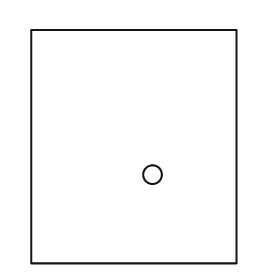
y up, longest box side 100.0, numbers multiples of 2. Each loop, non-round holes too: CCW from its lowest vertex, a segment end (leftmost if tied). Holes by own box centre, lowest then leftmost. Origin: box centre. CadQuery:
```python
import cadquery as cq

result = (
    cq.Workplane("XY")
    .moveTo(-44.0, -50.0)
    .lineTo(44.0, -50.0)
    .lineTo(44.0, 50.0)
    .lineTo(-44.0, 50.0)
    .close()
    .moveTo(8.0, -12.0)
    .circle(4.0)
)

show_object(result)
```